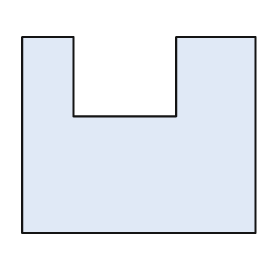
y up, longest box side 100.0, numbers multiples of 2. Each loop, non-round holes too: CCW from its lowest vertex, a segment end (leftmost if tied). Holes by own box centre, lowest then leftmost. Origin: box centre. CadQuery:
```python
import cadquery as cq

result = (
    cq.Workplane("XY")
    .moveTo(-50.0, -42.0)
    .lineTo(50.0, -42.0)
    .lineTo(50.0, 42.0)
    .lineTo(16.0, 42.0)
    .lineTo(16.0, 8.0)
    .lineTo(-28.0, 8.0)
    .lineTo(-28.0, 42.0)
    .lineTo(-50.0, 42.0)
    .close()
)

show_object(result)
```